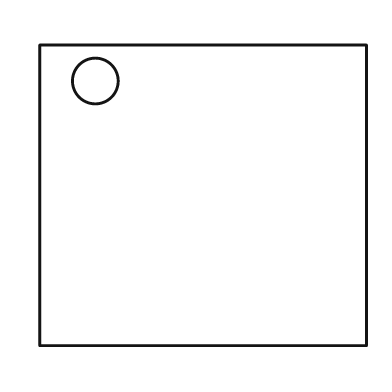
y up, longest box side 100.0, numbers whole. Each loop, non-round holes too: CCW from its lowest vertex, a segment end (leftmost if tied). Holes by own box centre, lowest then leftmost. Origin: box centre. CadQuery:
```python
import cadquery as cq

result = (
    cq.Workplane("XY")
    .moveTo(-50.0, -46.0)
    .lineTo(50.0, -46.0)
    .lineTo(50.0, 46.0)
    .lineTo(-50.0, 46.0)
    .close()
    .moveTo(-33.0, 35.0)
    .circle(7.0)
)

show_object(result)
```